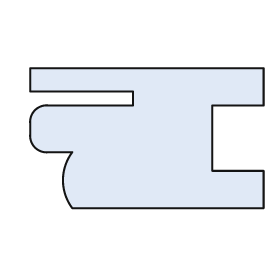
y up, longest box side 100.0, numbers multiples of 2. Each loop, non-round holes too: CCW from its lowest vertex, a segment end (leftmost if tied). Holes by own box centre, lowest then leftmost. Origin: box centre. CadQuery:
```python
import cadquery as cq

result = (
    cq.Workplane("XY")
    .moveTo(-32.0, -30.0)
    .lineTo(50.0, -30.0)
    .lineTo(50.0, -14.0)
    .lineTo(28.0, -14.0)
    .lineTo(28.0, 14.0)
    .lineTo(50.0, 14.0)
    .lineTo(50.0, 30.0)
    .lineTo(-50.0, 30.0)
    .lineTo(-50.0, 20.0)
    .lineTo(-6.0, 20.0)
    .lineTo(-6.0, 14.0)
    .lineTo(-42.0, 14.0)
    .threePointArc((-48.0, 12.0), (-50.0, 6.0))
    .lineTo(-50.0, 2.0)
    .threePointArc((-48.0, -4.0), (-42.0, -6.0))
    .lineTo(-32.0, -6.0)
    .threePointArc((-36.0, -18.0), (-32.0, -30.0))
    .close()
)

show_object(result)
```